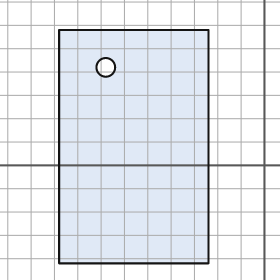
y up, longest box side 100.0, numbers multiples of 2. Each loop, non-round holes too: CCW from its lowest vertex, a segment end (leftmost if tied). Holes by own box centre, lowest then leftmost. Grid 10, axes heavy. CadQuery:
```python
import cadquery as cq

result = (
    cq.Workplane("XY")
    .moveTo(-88.0, -42.0)
    .lineTo(-24.0, -42.0)
    .lineTo(-24.0, 58.0)
    .lineTo(-88.0, 58.0)
    .close()
    .moveTo(-68.0, 42.0)
    .circle(4.0)
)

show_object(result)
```